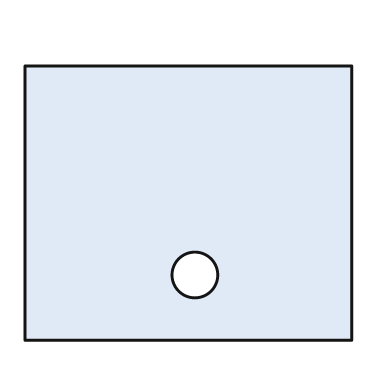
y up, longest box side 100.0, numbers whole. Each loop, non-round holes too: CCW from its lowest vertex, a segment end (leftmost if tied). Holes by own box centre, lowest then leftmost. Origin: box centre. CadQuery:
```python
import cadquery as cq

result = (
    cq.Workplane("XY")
    .moveTo(-50.0, -42.0)
    .lineTo(50.0, -42.0)
    .lineTo(50.0, 42.0)
    .lineTo(-50.0, 42.0)
    .close()
    .moveTo(2.0, -22.0)
    .circle(7.0)
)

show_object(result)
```